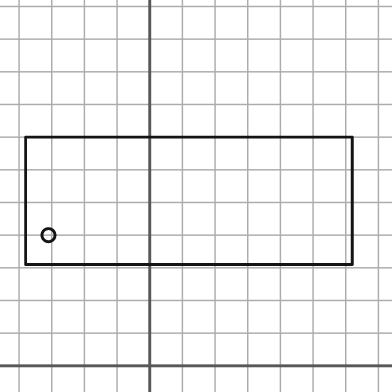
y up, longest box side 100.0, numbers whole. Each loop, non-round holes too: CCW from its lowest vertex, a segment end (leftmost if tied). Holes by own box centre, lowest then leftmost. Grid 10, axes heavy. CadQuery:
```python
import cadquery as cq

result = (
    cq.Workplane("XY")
    .moveTo(-38.0, 31.0)
    .lineTo(62.0, 31.0)
    .lineTo(62.0, 70.0)
    .lineTo(-38.0, 70.0)
    .close()
    .moveTo(-31.0, 40.0)
    .circle(2.0)
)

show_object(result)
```